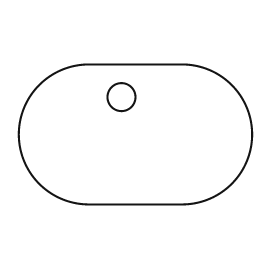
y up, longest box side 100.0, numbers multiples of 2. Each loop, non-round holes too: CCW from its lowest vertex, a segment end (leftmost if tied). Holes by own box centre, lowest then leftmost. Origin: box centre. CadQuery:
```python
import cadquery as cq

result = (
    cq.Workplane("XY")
    .moveTo(-20.0, -30.0)
    .lineTo(20.0, -30.0)
    .threePointArc((50.0, 0.0), (20.0, 30.0))
    .lineTo(-20.0, 30.0)
    .threePointArc((-50.0, 0.0), (-20.0, -30.0))
    .close()
    .moveTo(-6.0, 16.0)
    .circle(6.0)
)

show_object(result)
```